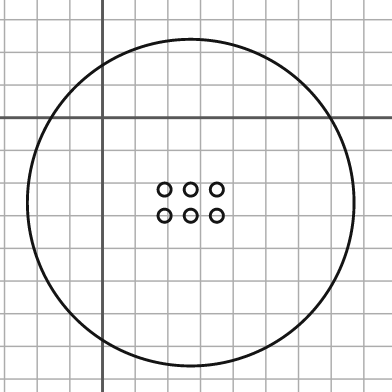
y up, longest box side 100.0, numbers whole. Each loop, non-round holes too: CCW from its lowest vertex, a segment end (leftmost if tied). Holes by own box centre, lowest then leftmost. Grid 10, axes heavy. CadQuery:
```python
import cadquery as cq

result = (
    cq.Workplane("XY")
    .moveTo(27.0, -26.0)
    .circle(50.0)
    .moveTo(19.0, -30.0)
    .circle(2.0)
    .moveTo(27.0, -30.0)
    .circle(2.0)
    .moveTo(35.0, -30.0)
    .circle(2.0)
    .moveTo(19.0, -22.0)
    .circle(2.0)
    .moveTo(27.0, -22.0)
    .circle(2.0)
    .moveTo(35.0, -22.0)
    .circle(2.0)
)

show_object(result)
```